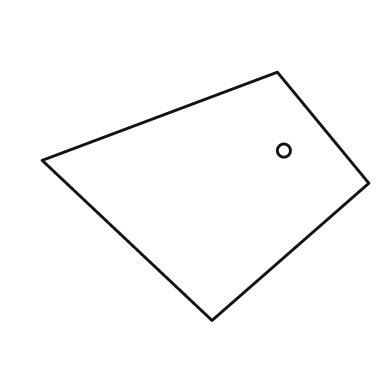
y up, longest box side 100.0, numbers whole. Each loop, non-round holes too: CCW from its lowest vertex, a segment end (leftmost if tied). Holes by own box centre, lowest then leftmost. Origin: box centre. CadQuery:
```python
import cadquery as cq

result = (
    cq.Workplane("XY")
    .moveTo(2.0, -38.0)
    .lineTo(50.0, 4.0)
    .lineTo(22.0, 38.0)
    .lineTo(-50.0, 11.0)
    .close()
    .moveTo(24.0, 14.0)
    .circle(2.0)
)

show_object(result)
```